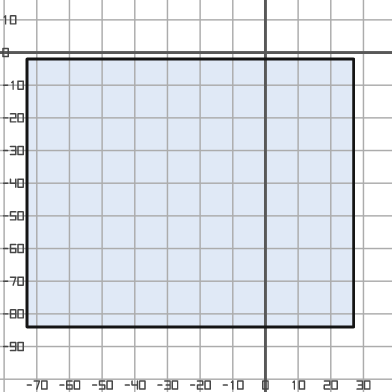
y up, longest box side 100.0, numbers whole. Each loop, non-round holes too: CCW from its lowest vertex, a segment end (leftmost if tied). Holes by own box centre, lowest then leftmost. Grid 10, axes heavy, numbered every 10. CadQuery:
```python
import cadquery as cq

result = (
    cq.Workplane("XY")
    .moveTo(-73.0, -84.0)
    .lineTo(27.0, -84.0)
    .lineTo(27.0, -2.0)
    .lineTo(-73.0, -2.0)
    .close()
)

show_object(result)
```